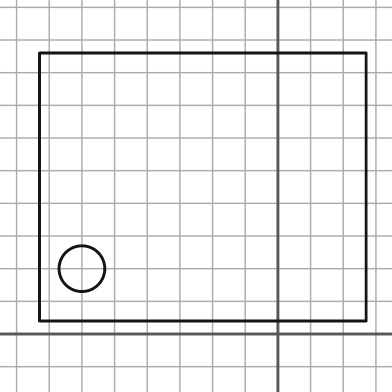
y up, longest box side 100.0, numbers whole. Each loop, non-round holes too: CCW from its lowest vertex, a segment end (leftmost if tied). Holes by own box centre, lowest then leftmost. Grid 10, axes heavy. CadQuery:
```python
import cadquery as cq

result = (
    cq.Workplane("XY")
    .moveTo(-73.0, 4.0)
    .lineTo(27.0, 4.0)
    .lineTo(27.0, 86.0)
    .lineTo(-73.0, 86.0)
    .close()
    .moveTo(-60.0, 20.0)
    .circle(7.0)
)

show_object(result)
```